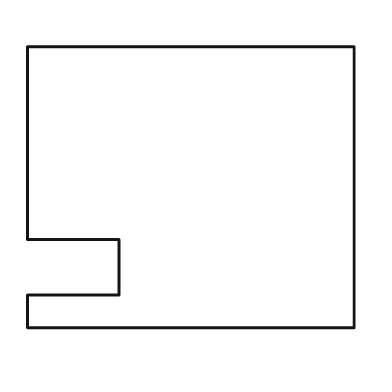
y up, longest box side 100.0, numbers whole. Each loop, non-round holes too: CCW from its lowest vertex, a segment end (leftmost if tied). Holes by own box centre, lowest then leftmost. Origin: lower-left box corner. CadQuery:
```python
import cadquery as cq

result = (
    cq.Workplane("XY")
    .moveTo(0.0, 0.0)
    .lineTo(100.0, 0.0)
    .lineTo(100.0, 86.0)
    .lineTo(0.0, 86.0)
    .lineTo(0.0, 27.0)
    .lineTo(28.0, 27.0)
    .lineTo(28.0, 10.0)
    .lineTo(0.0, 10.0)
    .close()
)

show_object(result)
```